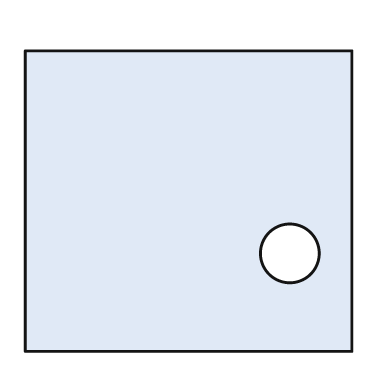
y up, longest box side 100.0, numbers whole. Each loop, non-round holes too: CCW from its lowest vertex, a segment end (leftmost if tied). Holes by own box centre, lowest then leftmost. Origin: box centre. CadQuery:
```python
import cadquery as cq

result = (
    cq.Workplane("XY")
    .moveTo(-50.0, -46.0)
    .lineTo(50.0, -46.0)
    .lineTo(50.0, 46.0)
    .lineTo(-50.0, 46.0)
    .close()
    .moveTo(31.0, -16.0)
    .circle(9.0)
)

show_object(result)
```